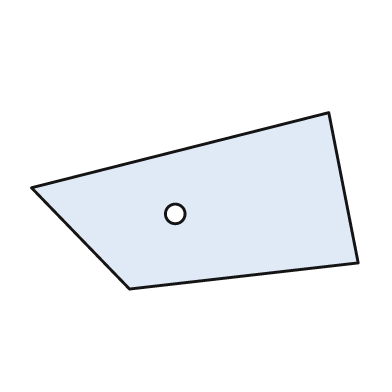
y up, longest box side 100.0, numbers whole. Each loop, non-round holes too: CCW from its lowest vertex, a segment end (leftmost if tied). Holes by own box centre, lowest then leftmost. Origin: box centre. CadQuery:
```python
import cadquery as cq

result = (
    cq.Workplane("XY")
    .moveTo(-20.0, -27.0)
    .lineTo(50.0, -19.0)
    .lineTo(41.0, 27.0)
    .lineTo(-50.0, 4.0)
    .close()
    .moveTo(-6.0, -4.0)
    .circle(3.0)
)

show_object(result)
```